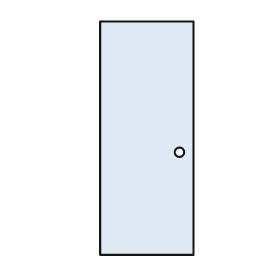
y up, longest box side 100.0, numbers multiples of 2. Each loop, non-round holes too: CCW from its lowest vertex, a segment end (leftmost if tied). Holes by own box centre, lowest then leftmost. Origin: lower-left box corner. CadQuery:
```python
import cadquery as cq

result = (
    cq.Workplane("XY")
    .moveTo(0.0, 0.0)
    .lineTo(40.0, 0.0)
    .lineTo(40.0, 100.0)
    .lineTo(0.0, 100.0)
    .close()
    .moveTo(34.0, 44.0)
    .circle(2.0)
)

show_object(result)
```